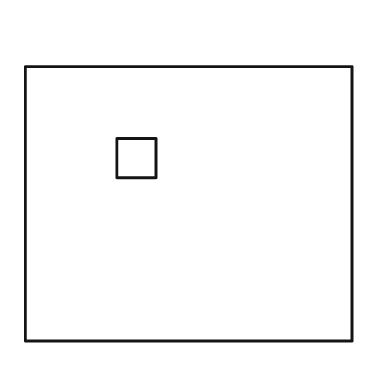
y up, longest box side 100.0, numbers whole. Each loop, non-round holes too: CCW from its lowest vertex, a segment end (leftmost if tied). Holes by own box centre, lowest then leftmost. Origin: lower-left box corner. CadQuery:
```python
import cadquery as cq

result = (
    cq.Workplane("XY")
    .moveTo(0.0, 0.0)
    .lineTo(100.0, 0.0)
    .lineTo(100.0, 84.0)
    .lineTo(0.0, 84.0)
    .close()
    .moveTo(28.0, 50.0)
    .lineTo(40.0, 50.0)
    .lineTo(40.0, 62.0)
    .lineTo(28.0, 62.0)
    .close()
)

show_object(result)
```